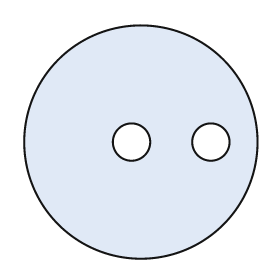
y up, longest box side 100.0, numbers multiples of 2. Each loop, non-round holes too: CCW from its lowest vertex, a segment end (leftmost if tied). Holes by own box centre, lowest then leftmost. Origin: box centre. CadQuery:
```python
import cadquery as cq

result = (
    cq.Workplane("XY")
    .moveTo(0.0, 0.0)
    .circle(50.0)
    .moveTo(-4.0, 0.0)
    .circle(8.0)
    .moveTo(30.0, 0.0)
    .circle(8.0)
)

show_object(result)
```